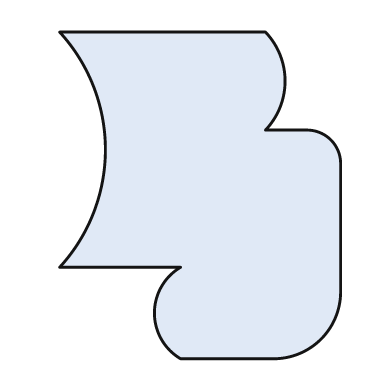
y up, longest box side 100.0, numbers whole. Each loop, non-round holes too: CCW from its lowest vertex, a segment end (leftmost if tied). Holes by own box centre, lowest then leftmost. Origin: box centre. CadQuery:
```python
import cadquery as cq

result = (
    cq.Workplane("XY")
    .moveTo(-6.0, -50.0)
    .lineTo(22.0, -50.0)
    .threePointArc((37.0, -44.0), (43.0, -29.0))
    .lineTo(43.0, 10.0)
    .threePointArc((40.0, 17.0), (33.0, 20.0))
    .lineTo(20.0, 20.0)
    .threePointArc((26.0, 35.0), (20.0, 50.0))
    .lineTo(-43.0, 50.0)
    .threePointArc((-29.0, 14.0), (-43.0, -22.0))
    .lineTo(-6.0, -22.0)
    .threePointArc((-14.0, -36.0), (-6.0, -50.0))
    .close()
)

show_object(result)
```